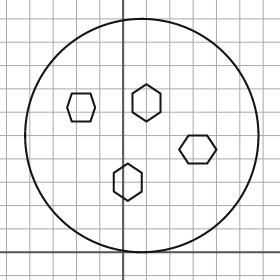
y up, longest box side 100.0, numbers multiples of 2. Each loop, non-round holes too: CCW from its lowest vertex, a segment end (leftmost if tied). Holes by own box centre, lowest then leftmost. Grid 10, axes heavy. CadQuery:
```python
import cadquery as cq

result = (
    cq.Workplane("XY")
    .moveTo(8.0, 50.0)
    .circle(50.0)
    .moveTo(2.0, 22.0)
    .lineTo(8.0, 26.0)
    .lineTo(8.0, 34.0)
    .lineTo(2.0, 38.0)
    .lineTo(-4.0, 34.0)
    .lineTo(-4.0, 26.0)
    .close()
    .moveTo(28.0, 38.0)
    .lineTo(36.0, 38.0)
    .lineTo(40.0, 44.0)
    .lineTo(36.0, 50.0)
    .lineTo(28.0, 50.0)
    .lineTo(24.0, 44.0)
    .close()
    .moveTo(-22.0, 56.0)
    .lineTo(-14.0, 56.0)
    .lineTo(-12.0, 62.0)
    .lineTo(-14.0, 68.0)
    .lineTo(-22.0, 68.0)
    .lineTo(-24.0, 62.0)
    .close()
    .moveTo(10.0, 56.0)
    .lineTo(16.0, 60.0)
    .lineTo(16.0, 68.0)
    .lineTo(10.0, 72.0)
    .lineTo(4.0, 68.0)
    .lineTo(4.0, 60.0)
    .close()
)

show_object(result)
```